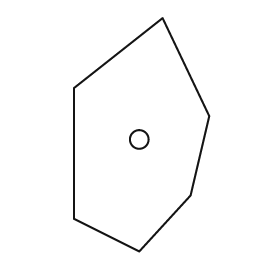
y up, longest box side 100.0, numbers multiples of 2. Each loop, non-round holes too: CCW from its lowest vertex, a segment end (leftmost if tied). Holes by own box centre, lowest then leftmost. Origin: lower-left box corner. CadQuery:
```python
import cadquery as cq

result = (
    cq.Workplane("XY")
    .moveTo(28.0, 0.0)
    .lineTo(50.0, 24.0)
    .lineTo(58.0, 58.0)
    .lineTo(38.0, 100.0)
    .lineTo(0.0, 70.0)
    .lineTo(0.0, 14.0)
    .close()
    .moveTo(28.0, 48.0)
    .circle(4.0)
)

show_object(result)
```